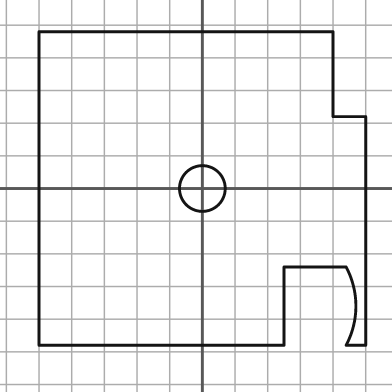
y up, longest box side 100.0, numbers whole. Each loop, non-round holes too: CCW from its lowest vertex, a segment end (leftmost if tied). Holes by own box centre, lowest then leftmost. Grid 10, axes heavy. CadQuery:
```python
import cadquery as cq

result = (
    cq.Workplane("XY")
    .moveTo(-50.0, -48.0)
    .lineTo(25.0, -48.0)
    .lineTo(25.0, -24.0)
    .lineTo(44.0, -24.0)
    .threePointArc((47.0, -36.0), (44.0, -48.0))
    .lineTo(50.0, -48.0)
    .lineTo(50.0, 22.0)
    .lineTo(40.0, 22.0)
    .lineTo(40.0, 48.0)
    .lineTo(-50.0, 48.0)
    .close()
    .moveTo(0.0, 0.0)
    .circle(7.0)
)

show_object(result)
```